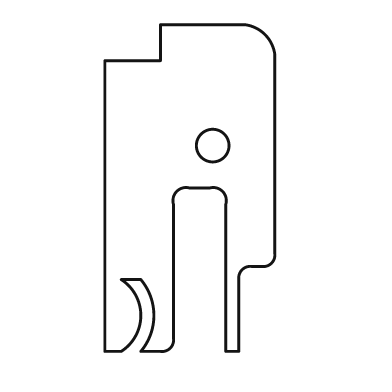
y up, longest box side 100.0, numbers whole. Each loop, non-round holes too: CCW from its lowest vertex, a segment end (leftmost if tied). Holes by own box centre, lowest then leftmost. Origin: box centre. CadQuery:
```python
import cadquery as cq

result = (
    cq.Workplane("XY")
    .moveTo(-26.0, -50.0)
    .lineTo(-21.0, -50.0)
    .threePointArc((-15.0, -39.0), (-21.0, -28.0))
    .lineTo(-15.0, -28.0)
    .threePointArc((-11.0, -39.0), (-15.0, -50.0))
    .lineTo(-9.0, -50.0)
    .threePointArc((-6.0, -49.0), (-5.0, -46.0))
    .lineTo(-5.0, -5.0)
    .threePointArc((-4.0, -1.0), (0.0, 0.0))
    .lineTo(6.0, 0.0)
    .threePointArc((10.0, -1.0), (11.0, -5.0))
    .lineTo(11.0, -50.0)
    .lineTo(15.0, -50.0)
    .lineTo(15.0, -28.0)
    .threePointArc((16.0, -25.0), (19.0, -24.0))
    .lineTo(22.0, -24.0)
    .threePointArc((25.0, -23.0), (26.0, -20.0))
    .lineTo(26.0, 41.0)
    .threePointArc((23.0, 47.0), (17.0, 50.0))
    .lineTo(-9.0, 50.0)
    .lineTo(-9.0, 39.0)
    .lineTo(-26.0, 39.0)
    .close()
    .moveTo(7.0, 13.0)
    .circle(5.0)
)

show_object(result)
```